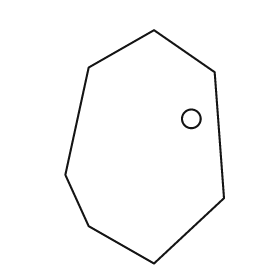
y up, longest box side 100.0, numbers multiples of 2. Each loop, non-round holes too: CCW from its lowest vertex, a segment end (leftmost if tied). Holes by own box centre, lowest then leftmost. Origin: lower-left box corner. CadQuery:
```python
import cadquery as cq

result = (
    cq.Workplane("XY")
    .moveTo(38.0, 0.0)
    .lineTo(68.0, 28.0)
    .lineTo(64.0, 82.0)
    .lineTo(38.0, 100.0)
    .lineTo(10.0, 84.0)
    .lineTo(0.0, 38.0)
    .lineTo(10.0, 16.0)
    .close()
    .moveTo(54.0, 62.0)
    .circle(4.0)
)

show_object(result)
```